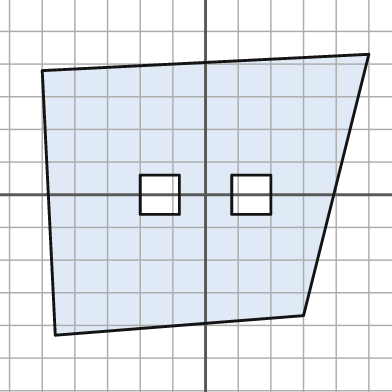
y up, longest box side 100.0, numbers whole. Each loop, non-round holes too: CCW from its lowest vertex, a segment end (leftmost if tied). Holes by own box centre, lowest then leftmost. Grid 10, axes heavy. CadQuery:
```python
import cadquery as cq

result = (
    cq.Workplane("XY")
    .moveTo(-46.0, -43.0)
    .lineTo(30.0, -37.0)
    .lineTo(50.0, 43.0)
    .lineTo(-50.0, 38.0)
    .close()
    .moveTo(-20.0, -6.0)
    .lineTo(-8.0, -6.0)
    .lineTo(-8.0, 6.0)
    .lineTo(-20.0, 6.0)
    .close()
    .moveTo(8.0, -6.0)
    .lineTo(20.0, -6.0)
    .lineTo(20.0, 6.0)
    .lineTo(8.0, 6.0)
    .close()
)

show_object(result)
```